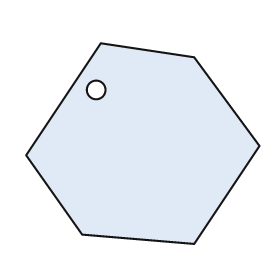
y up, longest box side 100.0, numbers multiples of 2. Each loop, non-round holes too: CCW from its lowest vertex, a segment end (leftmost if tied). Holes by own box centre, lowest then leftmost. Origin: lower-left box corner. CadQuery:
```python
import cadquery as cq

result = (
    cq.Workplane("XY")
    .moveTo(72.0, 0.0)
    .lineTo(100.0, 42.0)
    .lineTo(72.0, 80.0)
    .lineTo(32.0, 86.0)
    .lineTo(0.0, 38.0)
    .lineTo(24.0, 4.0)
    .close()
    .moveTo(30.0, 66.0)
    .circle(4.0)
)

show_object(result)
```